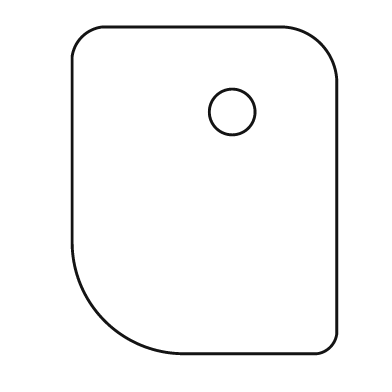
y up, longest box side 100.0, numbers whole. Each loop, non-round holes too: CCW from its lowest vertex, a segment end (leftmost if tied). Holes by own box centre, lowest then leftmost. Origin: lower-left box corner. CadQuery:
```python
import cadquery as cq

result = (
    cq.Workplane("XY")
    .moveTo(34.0, 0.0)
    .lineTo(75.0, 0.0)
    .threePointArc((79.0, 2.0), (81.0, 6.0))
    .lineTo(81.0, 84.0)
    .threePointArc((76.0, 95.0), (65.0, 100.0))
    .lineTo(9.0, 100.0)
    .threePointArc((3.0, 97.0), (0.0, 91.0))
    .lineTo(0.0, 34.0)
    .threePointArc((10.0, 10.0), (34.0, 0.0))
    .close()
    .moveTo(49.0, 74.0)
    .circle(7.0)
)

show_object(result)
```